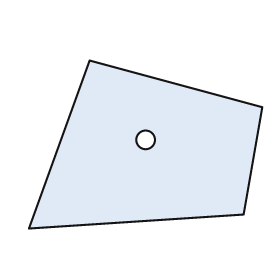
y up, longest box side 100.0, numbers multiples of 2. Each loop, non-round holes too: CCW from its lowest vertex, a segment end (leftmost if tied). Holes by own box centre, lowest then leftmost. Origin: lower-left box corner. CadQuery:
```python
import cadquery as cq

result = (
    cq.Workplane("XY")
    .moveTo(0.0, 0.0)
    .lineTo(92.0, 6.0)
    .lineTo(100.0, 52.0)
    .lineTo(26.0, 72.0)
    .close()
    .moveTo(50.0, 38.0)
    .circle(4.0)
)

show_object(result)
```